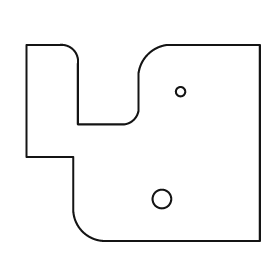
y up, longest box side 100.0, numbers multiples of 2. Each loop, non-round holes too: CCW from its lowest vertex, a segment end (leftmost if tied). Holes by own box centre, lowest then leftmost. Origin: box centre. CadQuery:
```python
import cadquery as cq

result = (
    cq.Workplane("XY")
    .moveTo(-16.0, -42.0)
    .lineTo(50.0, -42.0)
    .lineTo(50.0, 42.0)
    .lineTo(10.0, 42.0)
    .threePointArc((2.0, 38.0), (-2.0, 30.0))
    .lineTo(-2.0, 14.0)
    .threePointArc((-4.0, 10.0), (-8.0, 8.0))
    .lineTo(-28.0, 8.0)
    .lineTo(-28.0, 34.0)
    .threePointArc((-30.0, 40.0), (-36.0, 42.0))
    .lineTo(-50.0, 42.0)
    .lineTo(-50.0, -6.0)
    .lineTo(-30.0, -6.0)
    .lineTo(-30.0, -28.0)
    .threePointArc((-26.0, -38.0), (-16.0, -42.0))
    .close()
    .moveTo(8.0, -24.0)
    .circle(4.0)
    .moveTo(16.0, 22.0)
    .circle(2.0)
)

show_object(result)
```